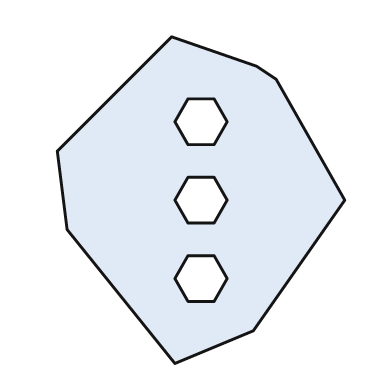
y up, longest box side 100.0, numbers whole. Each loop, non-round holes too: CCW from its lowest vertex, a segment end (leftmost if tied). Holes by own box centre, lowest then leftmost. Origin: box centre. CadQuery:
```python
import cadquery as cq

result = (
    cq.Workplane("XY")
    .moveTo(-8.0, -50.0)
    .lineTo(16.0, -40.0)
    .lineTo(44.0, 0.0)
    .lineTo(23.0, 37.0)
    .lineTo(17.0, 41.0)
    .lineTo(-9.0, 50.0)
    .lineTo(-44.0, 15.0)
    .lineTo(-41.0, -9.0)
    .close()
    .moveTo(-4.0, -31.0)
    .lineTo(4.0, -31.0)
    .lineTo(8.0, -24.0)
    .lineTo(4.0, -17.0)
    .lineTo(-4.0, -17.0)
    .lineTo(-8.0, -24.0)
    .close()
    .moveTo(-4.0, -7.0)
    .lineTo(4.0, -7.0)
    .lineTo(8.0, 0.0)
    .lineTo(4.0, 7.0)
    .lineTo(-4.0, 7.0)
    .lineTo(-8.0, 0.0)
    .close()
    .moveTo(-4.0, 17.0)
    .lineTo(4.0, 17.0)
    .lineTo(8.0, 24.0)
    .lineTo(4.0, 31.0)
    .lineTo(-4.0, 31.0)
    .lineTo(-8.0, 24.0)
    .close()
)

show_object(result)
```